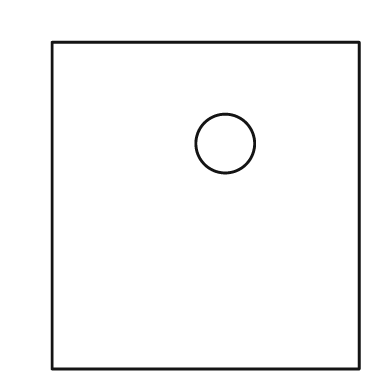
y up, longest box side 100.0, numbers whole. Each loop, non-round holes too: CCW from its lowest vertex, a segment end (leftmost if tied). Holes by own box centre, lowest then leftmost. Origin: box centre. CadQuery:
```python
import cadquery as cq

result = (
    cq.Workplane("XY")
    .moveTo(-47.0, -50.0)
    .lineTo(47.0, -50.0)
    .lineTo(47.0, 50.0)
    .lineTo(-47.0, 50.0)
    .close()
    .moveTo(6.0, 19.0)
    .circle(9.0)
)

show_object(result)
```